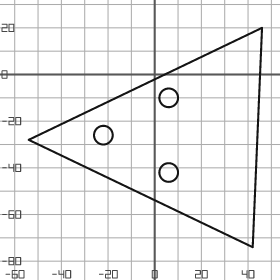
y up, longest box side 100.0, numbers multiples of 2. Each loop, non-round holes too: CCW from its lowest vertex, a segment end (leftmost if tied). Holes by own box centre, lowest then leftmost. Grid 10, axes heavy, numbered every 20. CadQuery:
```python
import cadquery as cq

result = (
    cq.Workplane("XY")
    .moveTo(42.0, -74.0)
    .lineTo(46.0, 20.0)
    .lineTo(-54.0, -28.0)
    .close()
    .moveTo(6.0, -42.0)
    .circle(4.0)
    .moveTo(-22.0, -26.0)
    .circle(4.0)
    .moveTo(6.0, -10.0)
    .circle(4.0)
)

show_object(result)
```